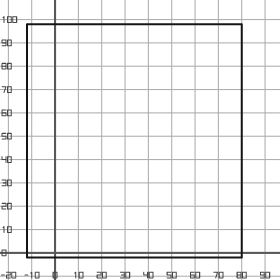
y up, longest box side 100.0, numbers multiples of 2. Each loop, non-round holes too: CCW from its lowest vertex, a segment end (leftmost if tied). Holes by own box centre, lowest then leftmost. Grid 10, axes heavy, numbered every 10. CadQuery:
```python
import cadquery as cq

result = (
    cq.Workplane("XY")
    .moveTo(-12.0, -2.0)
    .lineTo(80.0, -2.0)
    .lineTo(80.0, 98.0)
    .lineTo(-12.0, 98.0)
    .close()
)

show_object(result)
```